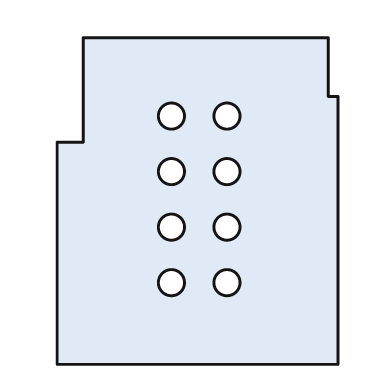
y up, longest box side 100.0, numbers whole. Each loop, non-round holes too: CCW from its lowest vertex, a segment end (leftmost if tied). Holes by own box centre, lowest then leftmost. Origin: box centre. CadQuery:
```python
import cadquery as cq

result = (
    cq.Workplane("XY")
    .moveTo(-43.0, -50.0)
    .lineTo(43.0, -50.0)
    .lineTo(43.0, 32.0)
    .lineTo(40.0, 32.0)
    .lineTo(40.0, 50.0)
    .lineTo(-35.0, 50.0)
    .lineTo(-35.0, 18.0)
    .lineTo(-43.0, 18.0)
    .close()
    .moveTo(-8.0, -25.0)
    .circle(4.0)
    .moveTo(9.0, -25.0)
    .circle(4.0)
    .moveTo(-8.0, -8.0)
    .circle(4.0)
    .moveTo(9.0, -8.0)
    .circle(4.0)
    .moveTo(-8.0, 9.0)
    .circle(4.0)
    .moveTo(9.0, 9.0)
    .circle(4.0)
    .moveTo(-8.0, 26.0)
    .circle(4.0)
    .moveTo(9.0, 26.0)
    .circle(4.0)
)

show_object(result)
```